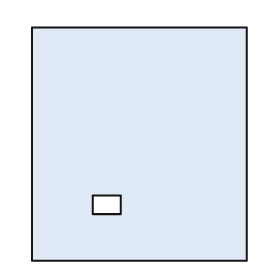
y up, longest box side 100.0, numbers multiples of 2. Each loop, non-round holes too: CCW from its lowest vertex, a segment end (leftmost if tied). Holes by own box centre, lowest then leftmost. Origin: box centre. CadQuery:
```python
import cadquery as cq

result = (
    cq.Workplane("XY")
    .moveTo(-46.0, -50.0)
    .lineTo(46.0, -50.0)
    .lineTo(46.0, 50.0)
    .lineTo(-46.0, 50.0)
    .close()
    .moveTo(-20.0, -30.0)
    .lineTo(-8.0, -30.0)
    .lineTo(-8.0, -22.0)
    .lineTo(-20.0, -22.0)
    .close()
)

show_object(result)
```